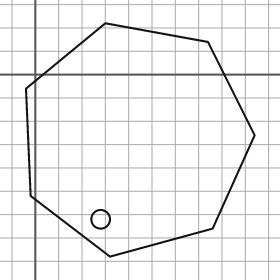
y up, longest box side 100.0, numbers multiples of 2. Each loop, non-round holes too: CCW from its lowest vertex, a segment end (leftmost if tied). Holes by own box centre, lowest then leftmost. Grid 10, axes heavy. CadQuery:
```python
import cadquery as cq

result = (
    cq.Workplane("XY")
    .moveTo(32.0, -78.0)
    .lineTo(76.0, -66.0)
    .lineTo(94.0, -26.0)
    .lineTo(74.0, 14.0)
    .lineTo(30.0, 22.0)
    .lineTo(-4.0, -6.0)
    .lineTo(-2.0, -52.0)
    .close()
    .moveTo(28.0, -62.0)
    .circle(4.0)
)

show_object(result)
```